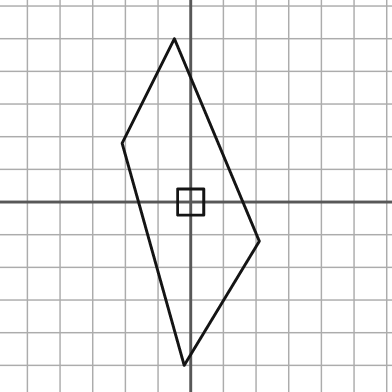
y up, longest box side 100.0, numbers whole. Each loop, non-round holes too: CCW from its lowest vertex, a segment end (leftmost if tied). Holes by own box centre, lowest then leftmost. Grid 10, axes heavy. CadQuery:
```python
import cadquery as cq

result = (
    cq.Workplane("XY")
    .moveTo(-2.0, -50.0)
    .lineTo(21.0, -12.0)
    .lineTo(-5.0, 50.0)
    .lineTo(-21.0, 18.0)
    .close()
    .moveTo(-4.0, -4.0)
    .lineTo(4.0, -4.0)
    .lineTo(4.0, 4.0)
    .lineTo(-4.0, 4.0)
    .close()
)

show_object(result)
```